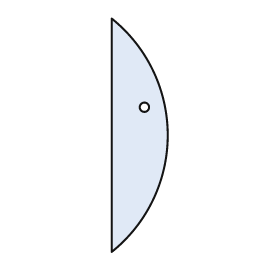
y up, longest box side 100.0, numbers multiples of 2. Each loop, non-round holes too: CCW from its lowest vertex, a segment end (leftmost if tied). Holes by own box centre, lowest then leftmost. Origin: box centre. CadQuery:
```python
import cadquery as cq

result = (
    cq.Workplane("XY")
    .moveTo(-12.0, -50.0)
    .threePointArc((12.0, 0.0), (-12.0, 50.0))
    .close()
    .moveTo(2.0, 12.0)
    .circle(2.0)
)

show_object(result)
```